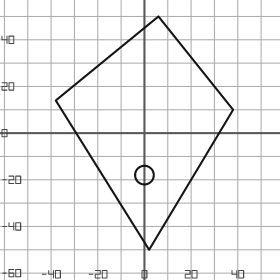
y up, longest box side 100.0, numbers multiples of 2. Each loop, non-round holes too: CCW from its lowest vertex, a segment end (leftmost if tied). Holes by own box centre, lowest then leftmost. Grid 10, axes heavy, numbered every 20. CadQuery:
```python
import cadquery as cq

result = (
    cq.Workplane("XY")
    .moveTo(2.0, -50.0)
    .lineTo(38.0, 10.0)
    .lineTo(6.0, 50.0)
    .lineTo(-38.0, 14.0)
    .close()
    .moveTo(0.0, -18.0)
    .circle(4.0)
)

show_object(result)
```